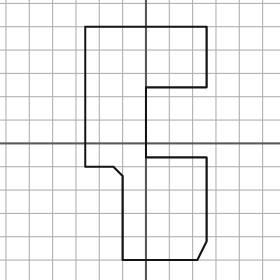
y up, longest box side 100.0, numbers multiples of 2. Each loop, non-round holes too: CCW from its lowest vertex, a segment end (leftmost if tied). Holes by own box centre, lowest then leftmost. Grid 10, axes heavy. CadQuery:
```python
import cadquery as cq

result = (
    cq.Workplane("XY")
    .moveTo(-10.0, -50.0)
    .lineTo(22.0, -50.0)
    .lineTo(26.0, -42.0)
    .lineTo(26.0, -6.0)
    .lineTo(0.0, -6.0)
    .lineTo(0.0, 24.0)
    .lineTo(26.0, 24.0)
    .lineTo(26.0, 50.0)
    .lineTo(-26.0, 50.0)
    .lineTo(-26.0, -10.0)
    .lineTo(-14.0, -10.0)
    .lineTo(-10.0, -14.0)
    .close()
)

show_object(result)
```